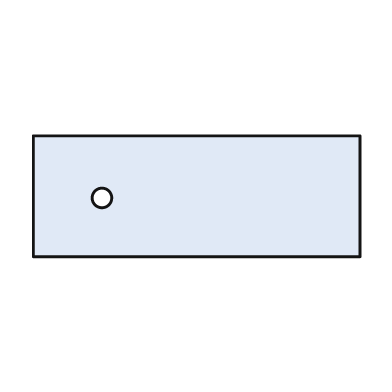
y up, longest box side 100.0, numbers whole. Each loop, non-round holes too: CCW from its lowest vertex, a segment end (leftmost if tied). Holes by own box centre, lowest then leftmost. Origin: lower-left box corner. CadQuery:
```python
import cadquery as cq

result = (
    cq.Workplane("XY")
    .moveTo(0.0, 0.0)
    .lineTo(100.0, 0.0)
    .lineTo(100.0, 37.0)
    .lineTo(0.0, 37.0)
    .close()
    .moveTo(21.0, 18.0)
    .circle(3.0)
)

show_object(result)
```